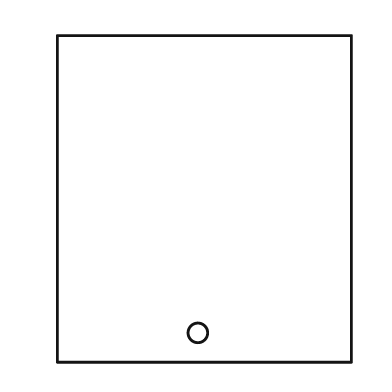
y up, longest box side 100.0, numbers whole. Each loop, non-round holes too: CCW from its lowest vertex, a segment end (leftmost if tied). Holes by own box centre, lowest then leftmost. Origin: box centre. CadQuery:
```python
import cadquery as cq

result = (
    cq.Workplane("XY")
    .moveTo(-45.0, -50.0)
    .lineTo(45.0, -50.0)
    .lineTo(45.0, 50.0)
    .lineTo(-45.0, 50.0)
    .close()
    .moveTo(-2.0, -41.0)
    .circle(3.0)
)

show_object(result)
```